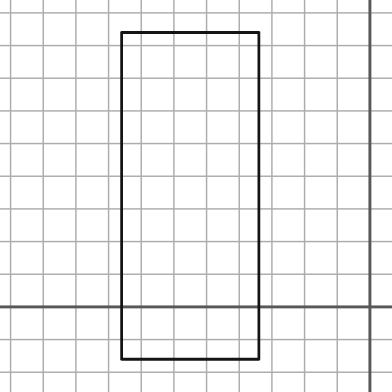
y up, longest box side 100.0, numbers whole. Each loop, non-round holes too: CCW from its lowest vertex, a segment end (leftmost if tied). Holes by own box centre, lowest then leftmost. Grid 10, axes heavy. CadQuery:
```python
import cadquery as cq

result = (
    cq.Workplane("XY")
    .moveTo(-76.0, -16.0)
    .lineTo(-34.0, -16.0)
    .lineTo(-34.0, 84.0)
    .lineTo(-76.0, 84.0)
    .close()
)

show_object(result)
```